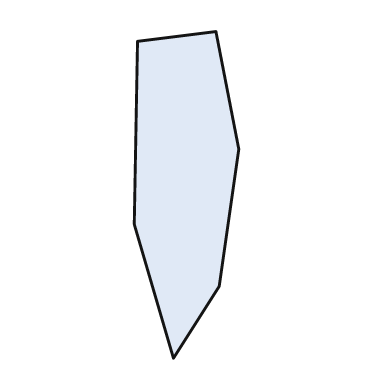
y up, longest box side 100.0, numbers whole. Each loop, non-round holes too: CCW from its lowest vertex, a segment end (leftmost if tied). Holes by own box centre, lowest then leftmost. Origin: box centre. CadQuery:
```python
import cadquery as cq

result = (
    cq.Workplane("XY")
    .moveTo(-4.0, -50.0)
    .lineTo(10.0, -28.0)
    .lineTo(16.0, 14.0)
    .lineTo(9.0, 50.0)
    .lineTo(-15.0, 47.0)
    .lineTo(-16.0, -9.0)
    .close()
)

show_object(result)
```